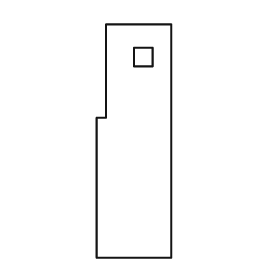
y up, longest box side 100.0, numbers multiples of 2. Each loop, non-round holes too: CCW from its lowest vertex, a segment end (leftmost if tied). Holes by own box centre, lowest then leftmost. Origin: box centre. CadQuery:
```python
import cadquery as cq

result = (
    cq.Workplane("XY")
    .moveTo(-16.0, -50.0)
    .lineTo(16.0, -50.0)
    .lineTo(16.0, 50.0)
    .lineTo(-12.0, 50.0)
    .lineTo(-12.0, 10.0)
    .lineTo(-16.0, 10.0)
    .close()
    .moveTo(0.0, 32.0)
    .lineTo(8.0, 32.0)
    .lineTo(8.0, 40.0)
    .lineTo(0.0, 40.0)
    .close()
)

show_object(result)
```